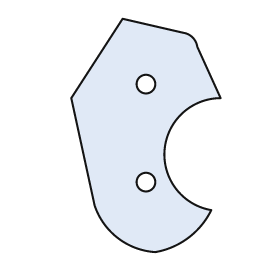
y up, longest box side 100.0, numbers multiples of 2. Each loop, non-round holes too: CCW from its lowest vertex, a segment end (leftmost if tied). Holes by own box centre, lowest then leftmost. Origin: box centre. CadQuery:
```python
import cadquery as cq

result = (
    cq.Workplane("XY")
    .moveTo(4.0, -50.0)
    .threePointArc((18.0, -44.0), (28.0, -32.0))
    .threePointArc((8.0, -6.0), (32.0, 16.0))
    .lineTo(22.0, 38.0)
    .threePointArc((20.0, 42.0), (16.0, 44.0))
    .lineTo(-10.0, 50.0)
    .lineTo(-32.0, 16.0)
    .lineTo(-22.0, -30.0)
    .threePointArc((-12.0, -44.0), (4.0, -50.0))
    .close()
    .moveTo(0.0, -20.0)
    .circle(4.0)
    .moveTo(0.0, 22.0)
    .circle(4.0)
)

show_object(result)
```